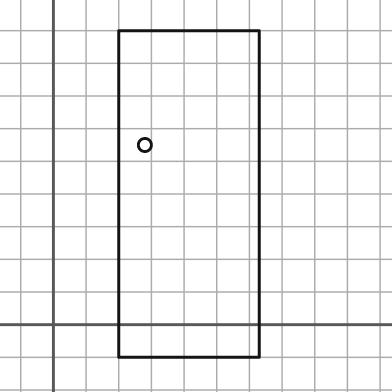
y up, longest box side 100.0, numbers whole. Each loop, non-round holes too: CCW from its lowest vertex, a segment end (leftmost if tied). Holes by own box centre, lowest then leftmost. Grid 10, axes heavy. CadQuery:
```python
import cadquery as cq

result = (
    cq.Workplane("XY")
    .moveTo(20.0, -10.0)
    .lineTo(63.0, -10.0)
    .lineTo(63.0, 90.0)
    .lineTo(20.0, 90.0)
    .close()
    .moveTo(28.0, 55.0)
    .circle(2.0)
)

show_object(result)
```